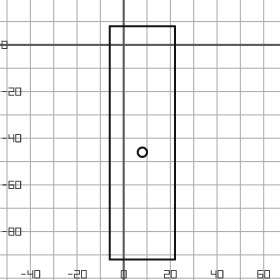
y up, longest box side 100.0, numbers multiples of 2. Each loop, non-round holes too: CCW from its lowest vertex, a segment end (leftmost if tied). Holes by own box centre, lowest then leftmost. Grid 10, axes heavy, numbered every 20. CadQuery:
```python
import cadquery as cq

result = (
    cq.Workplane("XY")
    .moveTo(-6.0, -92.0)
    .lineTo(22.0, -92.0)
    .lineTo(22.0, 8.0)
    .lineTo(-6.0, 8.0)
    .close()
    .moveTo(8.0, -46.0)
    .circle(2.0)
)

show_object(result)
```